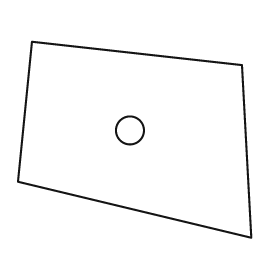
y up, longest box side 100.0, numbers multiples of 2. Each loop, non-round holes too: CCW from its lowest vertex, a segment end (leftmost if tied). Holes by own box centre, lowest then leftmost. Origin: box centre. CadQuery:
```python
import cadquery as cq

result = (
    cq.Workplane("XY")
    .moveTo(50.0, -42.0)
    .lineTo(46.0, 32.0)
    .lineTo(-44.0, 42.0)
    .lineTo(-50.0, -18.0)
    .close()
    .moveTo(-2.0, 4.0)
    .circle(6.0)
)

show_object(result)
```